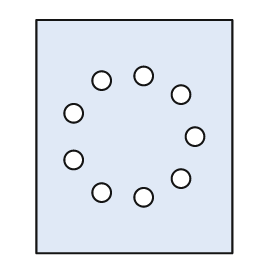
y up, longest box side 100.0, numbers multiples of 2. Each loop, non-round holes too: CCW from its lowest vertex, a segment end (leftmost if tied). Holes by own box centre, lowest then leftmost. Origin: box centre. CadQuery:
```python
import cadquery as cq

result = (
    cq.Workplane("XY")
    .moveTo(-42.0, -50.0)
    .lineTo(42.0, -50.0)
    .lineTo(42.0, 50.0)
    .lineTo(-42.0, 50.0)
    .close()
    .moveTo(4.0, -26.0)
    .circle(4.0)
    .moveTo(-14.0, -24.0)
    .circle(4.0)
    .moveTo(20.0, -18.0)
    .circle(4.0)
    .moveTo(-26.0, -10.0)
    .circle(4.0)
    .moveTo(26.0, 0.0)
    .circle(4.0)
    .moveTo(-26.0, 10.0)
    .circle(4.0)
    .moveTo(20.0, 18.0)
    .circle(4.0)
    .moveTo(-14.0, 24.0)
    .circle(4.0)
    .moveTo(4.0, 26.0)
    .circle(4.0)
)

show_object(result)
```